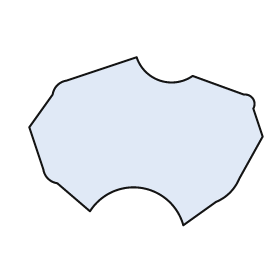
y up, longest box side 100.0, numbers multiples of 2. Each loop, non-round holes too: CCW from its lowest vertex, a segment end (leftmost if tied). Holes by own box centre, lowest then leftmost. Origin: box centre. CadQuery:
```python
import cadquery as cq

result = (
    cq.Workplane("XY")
    .moveTo(16.0, -36.0)
    .lineTo(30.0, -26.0)
    .threePointArc((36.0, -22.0), (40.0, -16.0))
    .lineTo(50.0, 2.0)
    .lineTo(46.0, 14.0)
    .threePointArc((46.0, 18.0), (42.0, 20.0))
    .lineTo(20.0, 28.0)
    .threePointArc((6.0, 26.0), (-4.0, 36.0))
    .lineTo(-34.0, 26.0)
    .threePointArc((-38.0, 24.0), (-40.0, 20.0))
    .lineTo(-50.0, 6.0)
    .lineTo(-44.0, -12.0)
    .threePointArc((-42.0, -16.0), (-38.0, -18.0))
    .lineTo(-24.0, -30.0)
    .threePointArc((-2.0, -20.0), (16.0, -36.0))
    .close()
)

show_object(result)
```